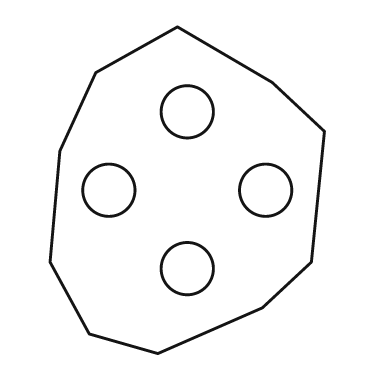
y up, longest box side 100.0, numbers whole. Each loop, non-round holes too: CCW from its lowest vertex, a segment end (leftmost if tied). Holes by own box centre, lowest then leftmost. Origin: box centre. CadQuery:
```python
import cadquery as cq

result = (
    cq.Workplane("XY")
    .moveTo(-9.0, -50.0)
    .lineTo(23.0, -36.0)
    .lineTo(38.0, -22.0)
    .lineTo(42.0, 18.0)
    .lineTo(26.0, 33.0)
    .lineTo(-3.0, 50.0)
    .lineTo(-28.0, 36.0)
    .lineTo(-39.0, 12.0)
    .lineTo(-42.0, -22.0)
    .lineTo(-30.0, -44.0)
    .close()
    .moveTo(0.0, -24.0)
    .circle(8.0)
    .moveTo(-24.0, 0.0)
    .circle(8.0)
    .moveTo(24.0, 0.0)
    .circle(8.0)
    .moveTo(0.0, 24.0)
    .circle(8.0)
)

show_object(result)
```